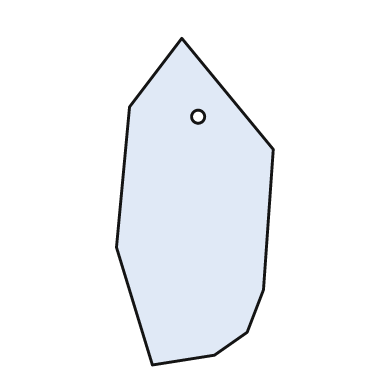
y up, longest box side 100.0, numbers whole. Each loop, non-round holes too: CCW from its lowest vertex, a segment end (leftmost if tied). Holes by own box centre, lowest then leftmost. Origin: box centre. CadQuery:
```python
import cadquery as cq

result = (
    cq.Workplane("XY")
    .moveTo(-13.0, -50.0)
    .lineTo(6.0, -47.0)
    .lineTo(16.0, -40.0)
    .lineTo(21.0, -27.0)
    .lineTo(24.0, 16.0)
    .lineTo(-4.0, 50.0)
    .lineTo(-20.0, 29.0)
    .lineTo(-24.0, -14.0)
    .close()
    .moveTo(1.0, 26.0)
    .circle(2.0)
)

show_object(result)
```